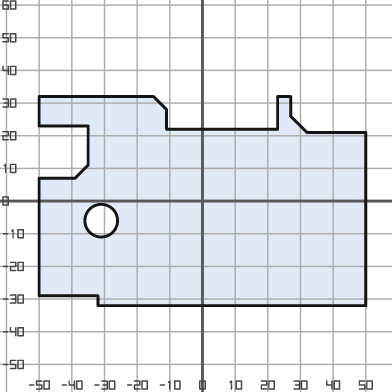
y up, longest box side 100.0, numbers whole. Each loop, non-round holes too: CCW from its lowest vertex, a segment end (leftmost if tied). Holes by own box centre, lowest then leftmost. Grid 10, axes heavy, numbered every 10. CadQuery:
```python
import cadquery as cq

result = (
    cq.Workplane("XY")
    .moveTo(-32.0, -32.0)
    .lineTo(50.0, -32.0)
    .lineTo(50.0, 21.0)
    .lineTo(32.0, 21.0)
    .lineTo(27.0, 26.0)
    .lineTo(27.0, 32.0)
    .lineTo(23.0, 32.0)
    .lineTo(23.0, 22.0)
    .lineTo(-11.0, 22.0)
    .lineTo(-11.0, 28.0)
    .lineTo(-15.0, 32.0)
    .lineTo(-50.0, 32.0)
    .lineTo(-50.0, 23.0)
    .lineTo(-35.0, 23.0)
    .lineTo(-35.0, 11.0)
    .lineTo(-39.0, 7.0)
    .lineTo(-50.0, 7.0)
    .lineTo(-50.0, -29.0)
    .lineTo(-32.0, -29.0)
    .close()
    .moveTo(-31.0, -6.0)
    .circle(5.0)
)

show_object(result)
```